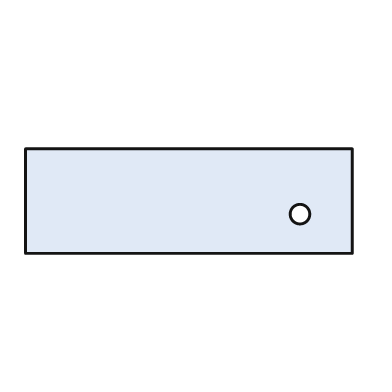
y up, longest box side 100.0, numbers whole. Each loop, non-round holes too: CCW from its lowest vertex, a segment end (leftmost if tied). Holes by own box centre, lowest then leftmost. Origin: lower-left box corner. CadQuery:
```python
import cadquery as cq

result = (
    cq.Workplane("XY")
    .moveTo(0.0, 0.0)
    .lineTo(100.0, 0.0)
    .lineTo(100.0, 32.0)
    .lineTo(0.0, 32.0)
    .close()
    .moveTo(84.0, 12.0)
    .circle(3.0)
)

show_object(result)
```